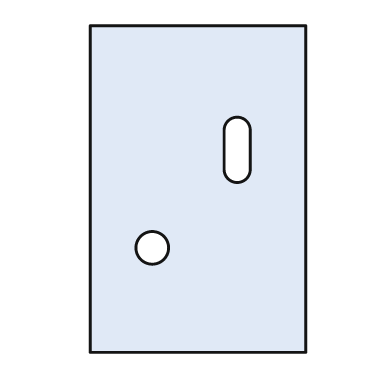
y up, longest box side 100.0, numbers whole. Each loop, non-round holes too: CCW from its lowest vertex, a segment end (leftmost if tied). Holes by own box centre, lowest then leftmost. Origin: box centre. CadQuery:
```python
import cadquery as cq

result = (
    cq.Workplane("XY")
    .moveTo(-33.0, -50.0)
    .lineTo(33.0, -50.0)
    .lineTo(33.0, 50.0)
    .lineTo(-33.0, 50.0)
    .close()
    .moveTo(-14.0, -18.0)
    .circle(5.0)
    .moveTo(8.0, 6.0)
    .threePointArc((12.0, 2.0), (16.0, 6.0))
    .lineTo(16.0, 18.0)
    .threePointArc((12.0, 22.0), (8.0, 18.0))
    .close()
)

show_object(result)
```